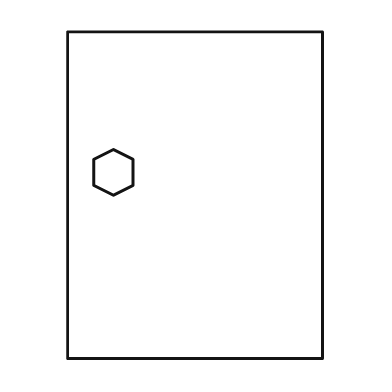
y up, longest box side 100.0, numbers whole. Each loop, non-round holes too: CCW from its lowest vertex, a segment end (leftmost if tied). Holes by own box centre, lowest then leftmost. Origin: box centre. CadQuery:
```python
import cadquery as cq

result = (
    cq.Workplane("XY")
    .moveTo(-39.0, -50.0)
    .lineTo(39.0, -50.0)
    .lineTo(39.0, 50.0)
    .lineTo(-39.0, 50.0)
    .close()
    .moveTo(-25.0, 0.0)
    .lineTo(-19.0, 3.0)
    .lineTo(-19.0, 11.0)
    .lineTo(-25.0, 14.0)
    .lineTo(-31.0, 11.0)
    .lineTo(-31.0, 3.0)
    .close()
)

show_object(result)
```